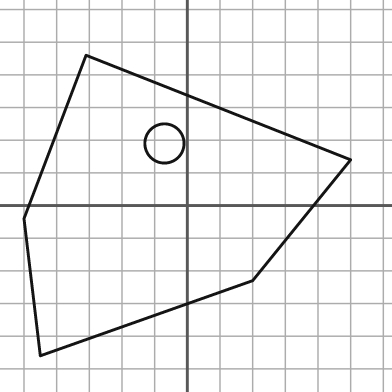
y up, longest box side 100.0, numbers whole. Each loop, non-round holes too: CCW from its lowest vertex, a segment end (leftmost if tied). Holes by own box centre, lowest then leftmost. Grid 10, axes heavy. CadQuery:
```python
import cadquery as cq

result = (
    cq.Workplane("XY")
    .moveTo(-45.0, -46.0)
    .lineTo(20.0, -23.0)
    .lineTo(50.0, 14.0)
    .lineTo(-31.0, 46.0)
    .lineTo(-50.0, -4.0)
    .close()
    .moveTo(-7.0, 19.0)
    .circle(6.0)
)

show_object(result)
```